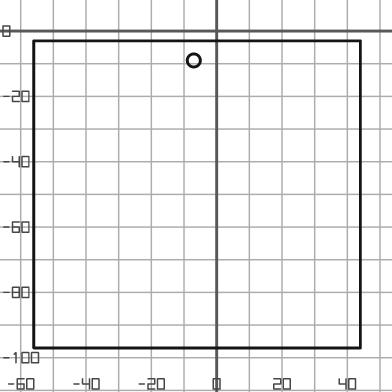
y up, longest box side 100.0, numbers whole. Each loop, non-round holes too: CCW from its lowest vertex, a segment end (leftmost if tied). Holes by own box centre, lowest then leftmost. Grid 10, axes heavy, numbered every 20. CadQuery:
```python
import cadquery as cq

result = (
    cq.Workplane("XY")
    .moveTo(-56.0, -97.0)
    .lineTo(44.0, -97.0)
    .lineTo(44.0, -3.0)
    .lineTo(-56.0, -3.0)
    .close()
    .moveTo(-7.0, -9.0)
    .circle(2.0)
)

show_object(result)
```